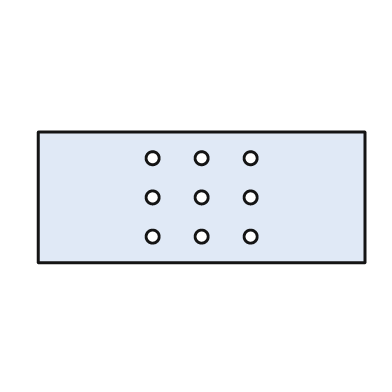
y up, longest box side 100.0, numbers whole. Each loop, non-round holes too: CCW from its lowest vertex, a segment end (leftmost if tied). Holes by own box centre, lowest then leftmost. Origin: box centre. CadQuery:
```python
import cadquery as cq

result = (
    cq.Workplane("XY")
    .moveTo(-50.0, -20.0)
    .lineTo(50.0, -20.0)
    .lineTo(50.0, 20.0)
    .lineTo(-50.0, 20.0)
    .close()
    .moveTo(-15.0, -12.0)
    .circle(2.0)
    .moveTo(0.0, -12.0)
    .circle(2.0)
    .moveTo(15.0, -12.0)
    .circle(2.0)
    .moveTo(-15.0, 0.0)
    .circle(2.0)
    .moveTo(0.0, 0.0)
    .circle(2.0)
    .moveTo(15.0, 0.0)
    .circle(2.0)
    .moveTo(-15.0, 12.0)
    .circle(2.0)
    .moveTo(0.0, 12.0)
    .circle(2.0)
    .moveTo(15.0, 12.0)
    .circle(2.0)
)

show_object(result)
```